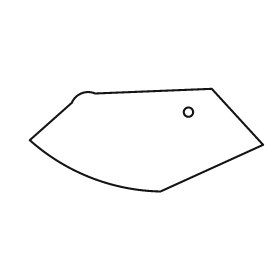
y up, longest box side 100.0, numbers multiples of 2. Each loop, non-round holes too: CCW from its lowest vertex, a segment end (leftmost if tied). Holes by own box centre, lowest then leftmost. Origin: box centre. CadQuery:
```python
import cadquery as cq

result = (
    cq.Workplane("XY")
    .moveTo(6.0, -22.0)
    .lineTo(50.0, -2.0)
    .lineTo(28.0, 22.0)
    .lineTo(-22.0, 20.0)
    .threePointArc((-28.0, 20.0), (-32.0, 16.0))
    .lineTo(-50.0, 0.0)
    .threePointArc((-24.0, -16.0), (6.0, -22.0))
    .close()
    .moveTo(18.0, 12.0)
    .circle(2.0)
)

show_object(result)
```